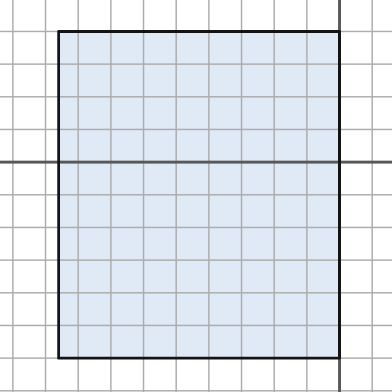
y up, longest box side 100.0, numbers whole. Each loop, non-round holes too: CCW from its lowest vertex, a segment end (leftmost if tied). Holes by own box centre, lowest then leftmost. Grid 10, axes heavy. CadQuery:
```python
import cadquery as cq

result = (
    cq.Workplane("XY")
    .moveTo(-86.0, -60.0)
    .lineTo(0.0, -60.0)
    .lineTo(0.0, 40.0)
    .lineTo(-86.0, 40.0)
    .close()
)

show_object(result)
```